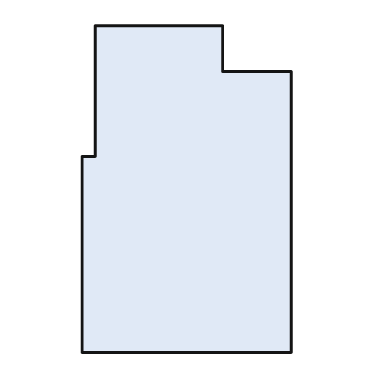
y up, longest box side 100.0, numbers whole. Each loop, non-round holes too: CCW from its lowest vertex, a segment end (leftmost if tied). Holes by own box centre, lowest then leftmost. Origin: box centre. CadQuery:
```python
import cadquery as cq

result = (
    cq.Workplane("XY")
    .moveTo(-32.0, -50.0)
    .lineTo(32.0, -50.0)
    .lineTo(32.0, 36.0)
    .lineTo(11.0, 36.0)
    .lineTo(11.0, 50.0)
    .lineTo(-28.0, 50.0)
    .lineTo(-28.0, 10.0)
    .lineTo(-32.0, 10.0)
    .close()
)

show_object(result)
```